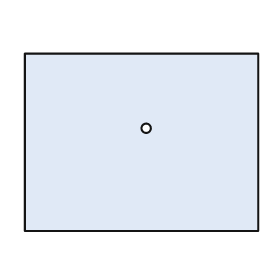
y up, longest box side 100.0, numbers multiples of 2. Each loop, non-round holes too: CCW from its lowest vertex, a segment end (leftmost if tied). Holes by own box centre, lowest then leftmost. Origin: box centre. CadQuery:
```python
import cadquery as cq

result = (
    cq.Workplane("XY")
    .moveTo(-50.0, -38.0)
    .lineTo(50.0, -38.0)
    .lineTo(50.0, 38.0)
    .lineTo(-50.0, 38.0)
    .close()
    .moveTo(2.0, 6.0)
    .circle(2.0)
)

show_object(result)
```